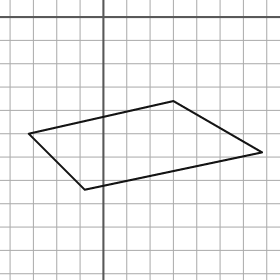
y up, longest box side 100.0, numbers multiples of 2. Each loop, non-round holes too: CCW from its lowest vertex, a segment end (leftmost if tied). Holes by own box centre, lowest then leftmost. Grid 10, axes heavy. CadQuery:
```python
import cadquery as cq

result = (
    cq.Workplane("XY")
    .moveTo(-8.0, -74.0)
    .lineTo(68.0, -58.0)
    .lineTo(30.0, -36.0)
    .lineTo(-32.0, -50.0)
    .close()
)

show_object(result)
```